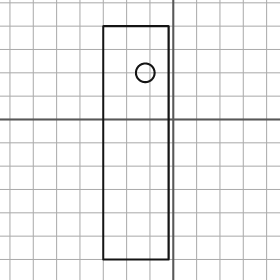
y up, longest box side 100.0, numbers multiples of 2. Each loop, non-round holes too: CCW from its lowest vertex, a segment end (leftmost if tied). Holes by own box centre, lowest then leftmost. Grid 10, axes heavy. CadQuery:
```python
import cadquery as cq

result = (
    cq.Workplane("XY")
    .moveTo(-30.0, -60.0)
    .lineTo(-2.0, -60.0)
    .lineTo(-2.0, 40.0)
    .lineTo(-30.0, 40.0)
    .close()
    .moveTo(-12.0, 20.0)
    .circle(4.0)
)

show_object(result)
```